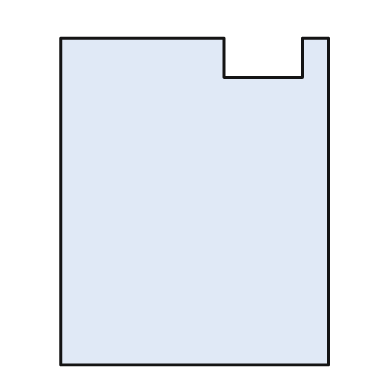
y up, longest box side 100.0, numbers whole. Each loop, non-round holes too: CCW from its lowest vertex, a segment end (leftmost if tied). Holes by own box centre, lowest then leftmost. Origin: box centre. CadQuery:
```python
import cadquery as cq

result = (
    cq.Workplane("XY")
    .moveTo(-41.0, -50.0)
    .lineTo(41.0, -50.0)
    .lineTo(41.0, 50.0)
    .lineTo(33.0, 50.0)
    .lineTo(33.0, 38.0)
    .lineTo(9.0, 38.0)
    .lineTo(9.0, 50.0)
    .lineTo(-41.0, 50.0)
    .close()
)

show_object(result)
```